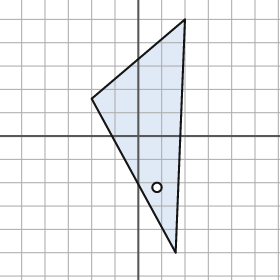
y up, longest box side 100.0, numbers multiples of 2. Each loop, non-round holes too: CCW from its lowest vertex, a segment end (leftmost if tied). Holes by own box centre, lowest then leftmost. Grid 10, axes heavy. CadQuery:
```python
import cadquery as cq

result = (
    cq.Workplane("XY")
    .moveTo(16.0, -50.0)
    .lineTo(20.0, 50.0)
    .lineTo(-20.0, 16.0)
    .close()
    .moveTo(8.0, -22.0)
    .circle(2.0)
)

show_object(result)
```